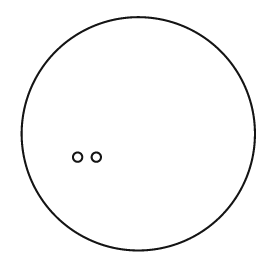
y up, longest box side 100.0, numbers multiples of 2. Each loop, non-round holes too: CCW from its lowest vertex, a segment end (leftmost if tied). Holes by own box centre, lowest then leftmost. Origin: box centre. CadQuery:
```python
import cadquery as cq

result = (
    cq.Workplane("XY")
    .moveTo(0.0, 0.0)
    .circle(50.0)
    .moveTo(-26.0, -10.0)
    .circle(2.0)
    .moveTo(-18.0, -10.0)
    .circle(2.0)
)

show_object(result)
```